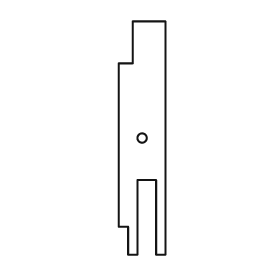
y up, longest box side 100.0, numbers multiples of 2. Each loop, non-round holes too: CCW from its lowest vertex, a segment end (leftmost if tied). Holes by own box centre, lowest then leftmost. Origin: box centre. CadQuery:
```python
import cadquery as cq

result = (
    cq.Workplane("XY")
    .moveTo(-6.0, -50.0)
    .lineTo(-2.0, -50.0)
    .lineTo(-2.0, -18.0)
    .lineTo(6.0, -18.0)
    .lineTo(6.0, -50.0)
    .lineTo(10.0, -50.0)
    .lineTo(10.0, 50.0)
    .lineTo(-4.0, 50.0)
    .lineTo(-4.0, 32.0)
    .lineTo(-10.0, 32.0)
    .lineTo(-10.0, -38.0)
    .lineTo(-6.0, -38.0)
    .close()
    .moveTo(0.0, 0.0)
    .circle(2.0)
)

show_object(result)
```